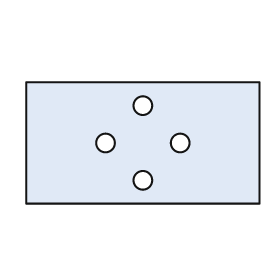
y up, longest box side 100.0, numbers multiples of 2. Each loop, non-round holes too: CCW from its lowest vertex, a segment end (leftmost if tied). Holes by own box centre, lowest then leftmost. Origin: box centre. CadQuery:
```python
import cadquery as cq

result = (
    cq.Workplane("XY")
    .moveTo(-50.0, -26.0)
    .lineTo(50.0, -26.0)
    .lineTo(50.0, 26.0)
    .lineTo(-50.0, 26.0)
    .close()
    .moveTo(0.0, -16.0)
    .circle(4.0)
    .moveTo(-16.0, 0.0)
    .circle(4.0)
    .moveTo(16.0, 0.0)
    .circle(4.0)
    .moveTo(0.0, 16.0)
    .circle(4.0)
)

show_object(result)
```